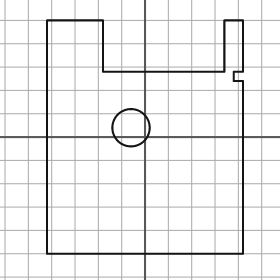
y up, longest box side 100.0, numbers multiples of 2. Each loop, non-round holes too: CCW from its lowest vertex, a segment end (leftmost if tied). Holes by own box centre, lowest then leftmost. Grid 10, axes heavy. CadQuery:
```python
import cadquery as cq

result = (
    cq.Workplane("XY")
    .moveTo(-42.0, -50.0)
    .lineTo(42.0, -50.0)
    .lineTo(42.0, 24.0)
    .lineTo(38.0, 24.0)
    .lineTo(38.0, 28.0)
    .lineTo(42.0, 28.0)
    .lineTo(42.0, 50.0)
    .lineTo(34.0, 50.0)
    .lineTo(34.0, 28.0)
    .lineTo(-18.0, 28.0)
    .lineTo(-18.0, 50.0)
    .lineTo(-42.0, 50.0)
    .close()
    .moveTo(-6.0, 4.0)
    .circle(8.0)
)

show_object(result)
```